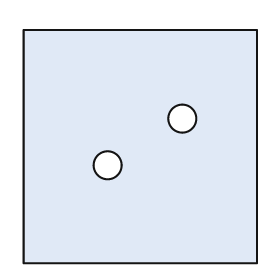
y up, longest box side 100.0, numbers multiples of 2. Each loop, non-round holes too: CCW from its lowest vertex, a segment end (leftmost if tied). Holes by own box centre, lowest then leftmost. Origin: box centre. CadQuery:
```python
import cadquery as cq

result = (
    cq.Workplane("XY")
    .moveTo(-50.0, -50.0)
    .lineTo(50.0, -50.0)
    .lineTo(50.0, 50.0)
    .lineTo(-50.0, 50.0)
    .close()
    .moveTo(-14.0, -8.0)
    .circle(6.0)
    .moveTo(18.0, 12.0)
    .circle(6.0)
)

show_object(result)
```